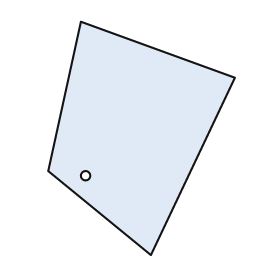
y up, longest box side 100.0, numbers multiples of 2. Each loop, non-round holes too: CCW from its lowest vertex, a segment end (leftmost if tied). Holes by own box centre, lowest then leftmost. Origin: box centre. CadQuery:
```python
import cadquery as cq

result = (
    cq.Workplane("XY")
    .moveTo(4.0, -50.0)
    .lineTo(40.0, 26.0)
    .lineTo(-26.0, 50.0)
    .lineTo(-40.0, -14.0)
    .close()
    .moveTo(-24.0, -16.0)
    .circle(2.0)
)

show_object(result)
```